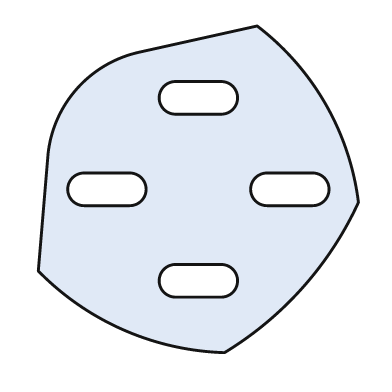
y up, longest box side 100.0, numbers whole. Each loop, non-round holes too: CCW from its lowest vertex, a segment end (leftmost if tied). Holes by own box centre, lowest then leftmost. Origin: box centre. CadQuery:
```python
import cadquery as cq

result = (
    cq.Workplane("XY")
    .moveTo(8.0, -50.0)
    .threePointArc((32.0, -30.0), (49.0, -4.0))
    .threePointArc((39.0, 26.0), (18.0, 50.0))
    .lineTo(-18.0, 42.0)
    .threePointArc((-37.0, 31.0), (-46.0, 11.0))
    .lineTo(-49.0, -25.0)
    .threePointArc((-23.0, -43.0), (8.0, -50.0))
    .close()
    .moveTo(-7.0, -33.0)
    .lineTo(7.0, -33.0)
    .threePointArc((12.0, -28.0), (7.0, -23.0))
    .lineTo(-7.0, -23.0)
    .threePointArc((-12.0, -28.0), (-7.0, -33.0))
    .close()
    .moveTo(-35.0, -5.0)
    .lineTo(-21.0, -5.0)
    .threePointArc((-16.0, 0.0), (-21.0, 5.0))
    .lineTo(-35.0, 5.0)
    .threePointArc((-40.0, 0.0), (-35.0, -5.0))
    .close()
    .moveTo(21.0, -5.0)
    .lineTo(35.0, -5.0)
    .threePointArc((40.0, 0.0), (35.0, 5.0))
    .lineTo(21.0, 5.0)
    .threePointArc((16.0, 0.0), (21.0, -5.0))
    .close()
    .moveTo(-7.0, 23.0)
    .lineTo(7.0, 23.0)
    .threePointArc((12.0, 28.0), (7.0, 33.0))
    .lineTo(-7.0, 33.0)
    .threePointArc((-12.0, 28.0), (-7.0, 23.0))
    .close()
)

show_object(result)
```